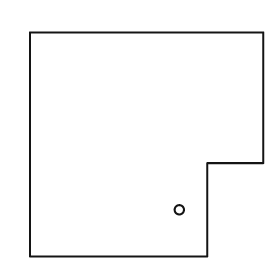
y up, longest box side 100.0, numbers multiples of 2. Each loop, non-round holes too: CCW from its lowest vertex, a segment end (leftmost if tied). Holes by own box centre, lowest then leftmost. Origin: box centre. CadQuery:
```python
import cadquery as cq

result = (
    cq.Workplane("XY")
    .moveTo(-50.0, -48.0)
    .lineTo(26.0, -48.0)
    .lineTo(26.0, -8.0)
    .lineTo(50.0, -8.0)
    .lineTo(50.0, 48.0)
    .lineTo(-50.0, 48.0)
    .close()
    .moveTo(14.0, -28.0)
    .circle(2.0)
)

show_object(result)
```